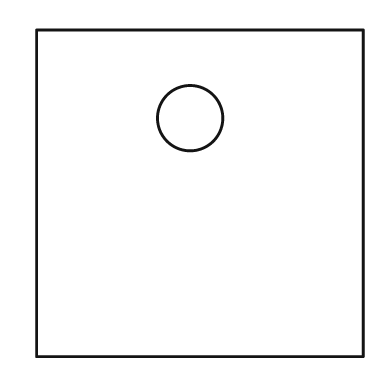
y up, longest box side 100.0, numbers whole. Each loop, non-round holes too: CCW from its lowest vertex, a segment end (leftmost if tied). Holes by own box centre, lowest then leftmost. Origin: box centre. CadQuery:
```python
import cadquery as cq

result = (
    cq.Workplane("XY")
    .moveTo(-50.0, -50.0)
    .lineTo(50.0, -50.0)
    .lineTo(50.0, 50.0)
    .lineTo(-50.0, 50.0)
    .close()
    .moveTo(-3.0, 23.0)
    .circle(10.0)
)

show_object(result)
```